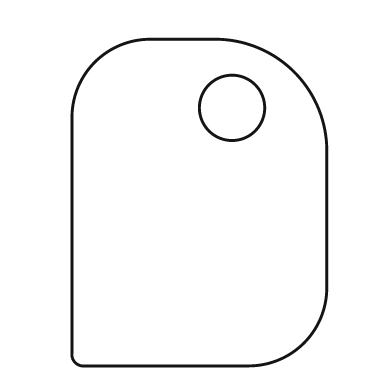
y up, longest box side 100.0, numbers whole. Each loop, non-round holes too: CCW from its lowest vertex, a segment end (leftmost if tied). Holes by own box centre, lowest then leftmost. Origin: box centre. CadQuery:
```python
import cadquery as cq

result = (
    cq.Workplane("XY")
    .moveTo(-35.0, -50.0)
    .lineTo(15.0, -50.0)
    .threePointArc((32.0, -43.0), (39.0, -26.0))
    .lineTo(39.0, 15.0)
    .threePointArc((29.0, 40.0), (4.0, 50.0))
    .lineTo(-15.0, 50.0)
    .threePointArc((-32.0, 43.0), (-39.0, 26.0))
    .lineTo(-39.0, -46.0)
    .threePointArc((-38.0, -49.0), (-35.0, -50.0))
    .close()
    .moveTo(10.0, 29.0)
    .circle(10.0)
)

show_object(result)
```